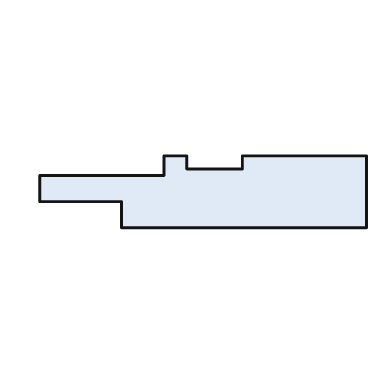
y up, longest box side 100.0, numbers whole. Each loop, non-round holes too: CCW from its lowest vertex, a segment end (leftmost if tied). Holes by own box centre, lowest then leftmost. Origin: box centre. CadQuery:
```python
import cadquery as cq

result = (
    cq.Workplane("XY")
    .moveTo(-25.0, -11.0)
    .lineTo(50.0, -11.0)
    .lineTo(50.0, 11.0)
    .lineTo(12.0, 11.0)
    .lineTo(12.0, 7.0)
    .lineTo(-5.0, 7.0)
    .lineTo(-5.0, 11.0)
    .lineTo(-12.0, 11.0)
    .lineTo(-12.0, 5.0)
    .lineTo(-50.0, 5.0)
    .lineTo(-50.0, -3.0)
    .lineTo(-25.0, -3.0)
    .close()
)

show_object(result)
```